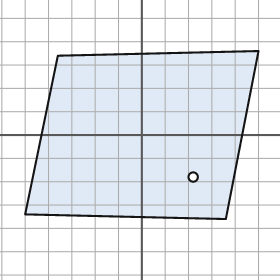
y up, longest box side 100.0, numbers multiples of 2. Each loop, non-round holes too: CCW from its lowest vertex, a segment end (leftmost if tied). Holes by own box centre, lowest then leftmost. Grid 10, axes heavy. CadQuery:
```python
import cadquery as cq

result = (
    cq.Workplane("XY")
    .moveTo(36.0, -36.0)
    .lineTo(50.0, 36.0)
    .lineTo(-36.0, 34.0)
    .lineTo(-50.0, -34.0)
    .close()
    .moveTo(22.0, -18.0)
    .circle(2.0)
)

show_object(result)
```